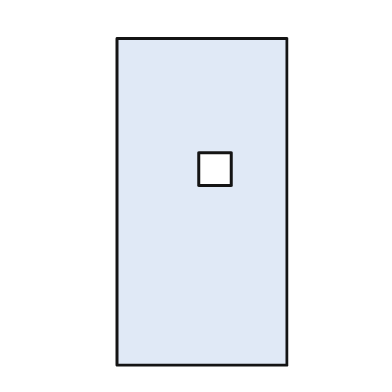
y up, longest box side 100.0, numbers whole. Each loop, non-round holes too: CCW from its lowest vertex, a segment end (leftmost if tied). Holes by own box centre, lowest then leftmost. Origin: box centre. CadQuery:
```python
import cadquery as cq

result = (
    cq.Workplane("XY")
    .moveTo(-26.0, -50.0)
    .lineTo(26.0, -50.0)
    .lineTo(26.0, 50.0)
    .lineTo(-26.0, 50.0)
    .close()
    .moveTo(-1.0, 5.0)
    .lineTo(9.0, 5.0)
    .lineTo(9.0, 15.0)
    .lineTo(-1.0, 15.0)
    .close()
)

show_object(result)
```